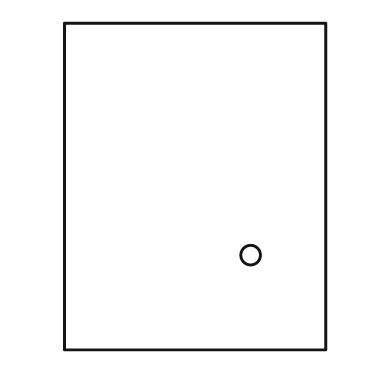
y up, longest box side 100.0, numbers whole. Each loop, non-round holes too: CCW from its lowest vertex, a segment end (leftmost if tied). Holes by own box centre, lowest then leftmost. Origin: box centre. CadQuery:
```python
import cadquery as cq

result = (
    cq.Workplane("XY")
    .moveTo(-40.0, -50.0)
    .lineTo(40.0, -50.0)
    .lineTo(40.0, 50.0)
    .lineTo(-40.0, 50.0)
    .close()
    .moveTo(17.0, -21.0)
    .circle(3.0)
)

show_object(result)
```